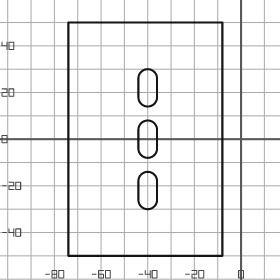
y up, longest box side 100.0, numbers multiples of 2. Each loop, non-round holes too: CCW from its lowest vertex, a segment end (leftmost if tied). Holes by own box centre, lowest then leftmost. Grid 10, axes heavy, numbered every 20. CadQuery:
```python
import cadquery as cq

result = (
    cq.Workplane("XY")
    .moveTo(-74.0, -50.0)
    .lineTo(-8.0, -50.0)
    .lineTo(-8.0, 50.0)
    .lineTo(-74.0, 50.0)
    .close()
    .moveTo(-44.0, -26.0)
    .threePointArc((-40.0, -30.0), (-36.0, -26.0))
    .lineTo(-36.0, -18.0)
    .threePointArc((-40.0, -14.0), (-44.0, -18.0))
    .close()
    .moveTo(-44.0, -4.0)
    .threePointArc((-40.0, -8.0), (-36.0, -4.0))
    .lineTo(-36.0, 4.0)
    .threePointArc((-40.0, 8.0), (-44.0, 4.0))
    .close()
    .moveTo(-44.0, 18.0)
    .threePointArc((-40.0, 14.0), (-36.0, 18.0))
    .lineTo(-36.0, 26.0)
    .threePointArc((-40.0, 30.0), (-44.0, 26.0))
    .close()
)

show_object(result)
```